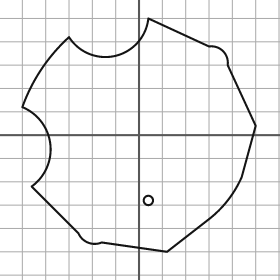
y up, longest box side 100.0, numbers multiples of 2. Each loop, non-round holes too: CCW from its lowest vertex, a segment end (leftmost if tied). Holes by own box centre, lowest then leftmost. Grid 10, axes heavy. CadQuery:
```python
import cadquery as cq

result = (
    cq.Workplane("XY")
    .moveTo(12.0, -50.0)
    .lineTo(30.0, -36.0)
    .threePointArc((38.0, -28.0), (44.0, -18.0))
    .lineTo(50.0, 4.0)
    .lineTo(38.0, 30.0)
    .threePointArc((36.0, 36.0), (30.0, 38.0))
    .lineTo(4.0, 50.0)
    .threePointArc((-10.0, 34.0), (-30.0, 42.0))
    .threePointArc((-42.0, 28.0), (-50.0, 12.0))
    .threePointArc((-38.0, -4.0), (-46.0, -22.0))
    .lineTo(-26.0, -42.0)
    .threePointArc((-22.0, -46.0), (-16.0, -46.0))
    .close()
    .moveTo(4.0, -28.0)
    .circle(2.0)
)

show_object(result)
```